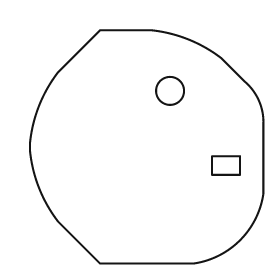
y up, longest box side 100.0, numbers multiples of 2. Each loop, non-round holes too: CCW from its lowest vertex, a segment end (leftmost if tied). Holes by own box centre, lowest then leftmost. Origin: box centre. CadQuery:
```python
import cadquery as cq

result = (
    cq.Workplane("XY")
    .moveTo(-20.0, -50.0)
    .lineTo(20.0, -50.0)
    .threePointArc((40.0, -40.0), (50.0, -20.0))
    .lineTo(50.0, 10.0)
    .threePointArc((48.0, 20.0), (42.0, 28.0))
    .lineTo(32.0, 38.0)
    .threePointArc((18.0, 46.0), (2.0, 50.0))
    .lineTo(-20.0, 50.0)
    .lineTo(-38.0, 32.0)
    .threePointArc((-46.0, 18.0), (-50.0, 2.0))
    .lineTo(-50.0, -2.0)
    .threePointArc((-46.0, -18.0), (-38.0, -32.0))
    .close()
    .moveTo(28.0, -12.0)
    .lineTo(40.0, -12.0)
    .lineTo(40.0, -4.0)
    .lineTo(28.0, -4.0)
    .close()
    .moveTo(10.0, 24.0)
    .circle(6.0)
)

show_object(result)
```